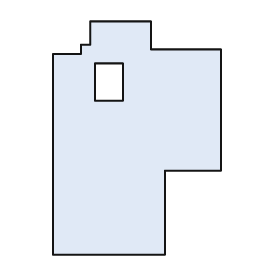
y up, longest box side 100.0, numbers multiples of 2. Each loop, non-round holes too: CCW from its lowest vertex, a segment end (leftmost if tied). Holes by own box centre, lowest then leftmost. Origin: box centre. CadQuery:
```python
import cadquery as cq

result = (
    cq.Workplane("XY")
    .moveTo(-36.0, -50.0)
    .lineTo(12.0, -50.0)
    .lineTo(12.0, -14.0)
    .lineTo(36.0, -14.0)
    .lineTo(36.0, 38.0)
    .lineTo(6.0, 38.0)
    .lineTo(6.0, 50.0)
    .lineTo(-20.0, 50.0)
    .lineTo(-20.0, 40.0)
    .lineTo(-24.0, 40.0)
    .lineTo(-24.0, 36.0)
    .lineTo(-36.0, 36.0)
    .close()
    .moveTo(-18.0, 16.0)
    .lineTo(-6.0, 16.0)
    .lineTo(-6.0, 32.0)
    .lineTo(-18.0, 32.0)
    .close()
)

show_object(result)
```